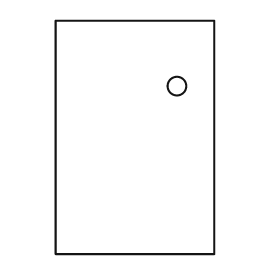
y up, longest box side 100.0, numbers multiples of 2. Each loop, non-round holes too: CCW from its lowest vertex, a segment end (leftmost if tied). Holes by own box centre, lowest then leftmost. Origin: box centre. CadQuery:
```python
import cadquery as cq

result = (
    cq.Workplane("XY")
    .moveTo(-34.0, -50.0)
    .lineTo(34.0, -50.0)
    .lineTo(34.0, 50.0)
    .lineTo(-34.0, 50.0)
    .close()
    .moveTo(18.0, 22.0)
    .circle(4.0)
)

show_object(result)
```